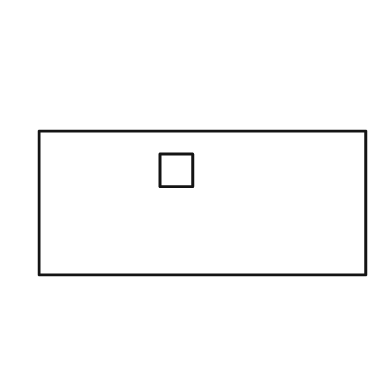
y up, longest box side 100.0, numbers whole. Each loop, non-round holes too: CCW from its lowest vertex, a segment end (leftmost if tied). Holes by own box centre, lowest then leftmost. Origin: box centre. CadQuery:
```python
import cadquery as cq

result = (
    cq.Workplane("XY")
    .moveTo(-50.0, -22.0)
    .lineTo(50.0, -22.0)
    .lineTo(50.0, 22.0)
    .lineTo(-50.0, 22.0)
    .close()
    .moveTo(-13.0, 5.0)
    .lineTo(-3.0, 5.0)
    .lineTo(-3.0, 15.0)
    .lineTo(-13.0, 15.0)
    .close()
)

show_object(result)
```